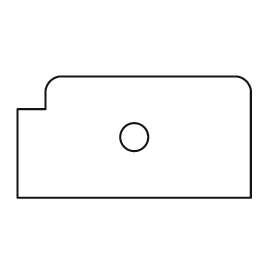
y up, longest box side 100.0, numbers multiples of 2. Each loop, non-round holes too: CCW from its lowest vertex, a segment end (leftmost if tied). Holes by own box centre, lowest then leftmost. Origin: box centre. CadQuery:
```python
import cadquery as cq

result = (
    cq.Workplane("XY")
    .moveTo(-50.0, -26.0)
    .lineTo(50.0, -26.0)
    .lineTo(50.0, 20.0)
    .threePointArc((48.0, 24.0), (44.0, 26.0))
    .lineTo(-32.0, 26.0)
    .threePointArc((-36.0, 24.0), (-38.0, 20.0))
    .lineTo(-38.0, 12.0)
    .lineTo(-50.0, 12.0)
    .close()
    .moveTo(0.0, 0.0)
    .circle(6.0)
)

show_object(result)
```